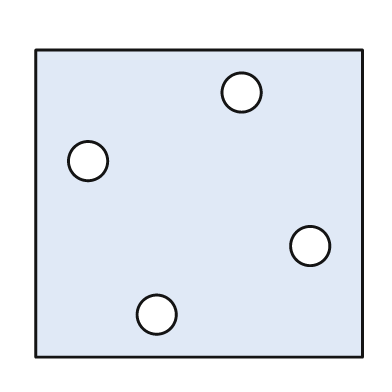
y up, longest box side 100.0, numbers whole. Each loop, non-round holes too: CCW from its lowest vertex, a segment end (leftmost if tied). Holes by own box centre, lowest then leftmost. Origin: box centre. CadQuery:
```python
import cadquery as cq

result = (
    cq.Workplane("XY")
    .moveTo(-50.0, -47.0)
    .lineTo(50.0, -47.0)
    .lineTo(50.0, 47.0)
    .lineTo(-50.0, 47.0)
    .close()
    .moveTo(-13.0, -34.0)
    .circle(6.0)
    .moveTo(34.0, -13.0)
    .circle(6.0)
    .moveTo(-34.0, 13.0)
    .circle(6.0)
    .moveTo(13.0, 34.0)
    .circle(6.0)
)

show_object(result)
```